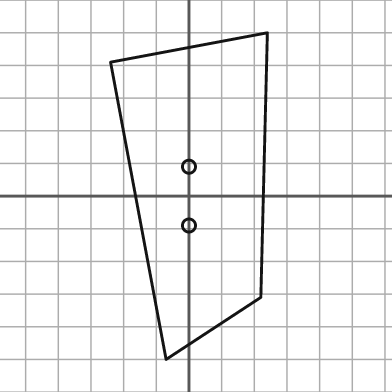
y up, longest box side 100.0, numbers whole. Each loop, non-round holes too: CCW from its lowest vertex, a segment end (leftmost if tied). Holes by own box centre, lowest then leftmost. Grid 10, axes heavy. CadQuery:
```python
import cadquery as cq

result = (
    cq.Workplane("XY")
    .moveTo(-7.0, -50.0)
    .lineTo(22.0, -31.0)
    .lineTo(24.0, 50.0)
    .lineTo(-24.0, 41.0)
    .close()
    .moveTo(0.0, -9.0)
    .circle(2.0)
    .moveTo(0.0, 9.0)
    .circle(2.0)
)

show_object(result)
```